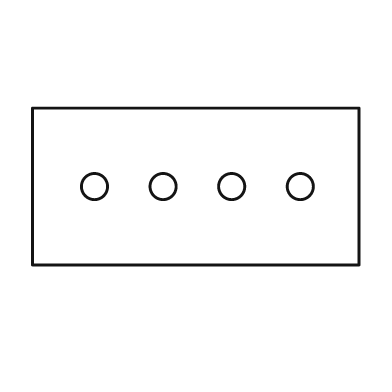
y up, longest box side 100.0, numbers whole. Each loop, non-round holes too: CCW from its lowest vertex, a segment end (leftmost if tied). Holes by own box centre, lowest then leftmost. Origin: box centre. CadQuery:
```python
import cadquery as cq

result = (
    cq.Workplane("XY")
    .moveTo(-50.0, -24.0)
    .lineTo(50.0, -24.0)
    .lineTo(50.0, 24.0)
    .lineTo(-50.0, 24.0)
    .close()
    .moveTo(-31.0, 0.0)
    .circle(4.0)
    .moveTo(-10.0, 0.0)
    .circle(4.0)
    .moveTo(11.0, 0.0)
    .circle(4.0)
    .moveTo(32.0, 0.0)
    .circle(4.0)
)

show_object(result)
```